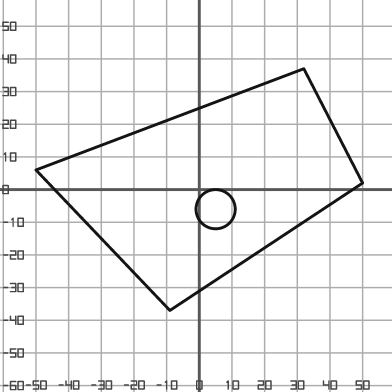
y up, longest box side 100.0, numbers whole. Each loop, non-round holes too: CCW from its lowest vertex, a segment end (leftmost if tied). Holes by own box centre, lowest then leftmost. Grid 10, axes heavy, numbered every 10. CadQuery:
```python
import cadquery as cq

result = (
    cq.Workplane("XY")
    .moveTo(-9.0, -37.0)
    .lineTo(50.0, 2.0)
    .lineTo(32.0, 37.0)
    .lineTo(-50.0, 6.0)
    .close()
    .moveTo(5.0, -6.0)
    .circle(6.0)
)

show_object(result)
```